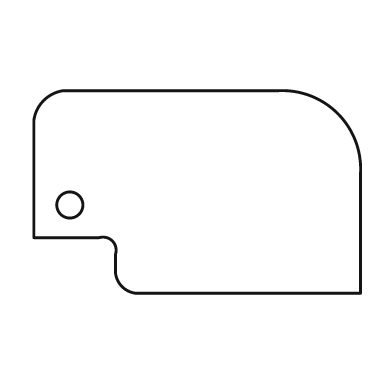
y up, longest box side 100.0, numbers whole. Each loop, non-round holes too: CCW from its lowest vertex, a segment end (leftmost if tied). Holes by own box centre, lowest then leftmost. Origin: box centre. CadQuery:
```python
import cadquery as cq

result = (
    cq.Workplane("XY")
    .moveTo(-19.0, -31.0)
    .lineTo(50.0, -31.0)
    .lineTo(50.0, 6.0)
    .threePointArc((43.0, 24.0), (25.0, 31.0))
    .lineTo(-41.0, 31.0)
    .threePointArc((-47.0, 28.0), (-50.0, 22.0))
    .lineTo(-50.0, -14.0)
    .lineTo(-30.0, -14.0)
    .threePointArc((-26.0, -15.0), (-25.0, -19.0))
    .lineTo(-25.0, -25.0)
    .threePointArc((-23.0, -29.0), (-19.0, -31.0))
    .close()
    .moveTo(-39.0, -4.0)
    .circle(4.0)
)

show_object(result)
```